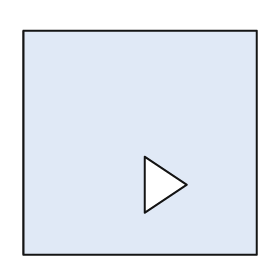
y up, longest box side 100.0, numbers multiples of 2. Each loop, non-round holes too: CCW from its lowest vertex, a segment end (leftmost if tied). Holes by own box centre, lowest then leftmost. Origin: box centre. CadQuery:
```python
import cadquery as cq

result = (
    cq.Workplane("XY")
    .moveTo(-50.0, -48.0)
    .lineTo(50.0, -48.0)
    .lineTo(50.0, 48.0)
    .lineTo(-50.0, 48.0)
    .close()
    .moveTo(2.0, -30.0)
    .lineTo(20.0, -18.0)
    .lineTo(2.0, -6.0)
    .close()
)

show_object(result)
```